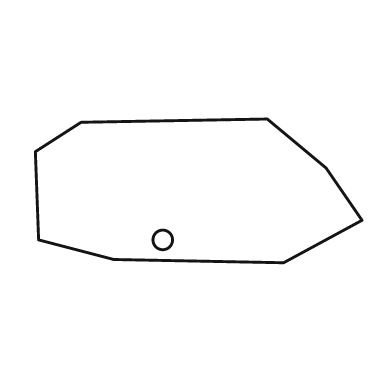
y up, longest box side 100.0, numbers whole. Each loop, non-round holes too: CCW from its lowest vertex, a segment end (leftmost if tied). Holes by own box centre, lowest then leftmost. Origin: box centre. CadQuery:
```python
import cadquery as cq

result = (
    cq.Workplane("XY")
    .moveTo(26.0, -22.0)
    .lineTo(50.0, -9.0)
    .lineTo(39.0, 7.0)
    .lineTo(21.0, 22.0)
    .lineTo(-36.0, 21.0)
    .lineTo(-50.0, 12.0)
    .lineTo(-49.0, -15.0)
    .lineTo(-26.0, -21.0)
    .close()
    .moveTo(-11.0, -15.0)
    .circle(3.0)
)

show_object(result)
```